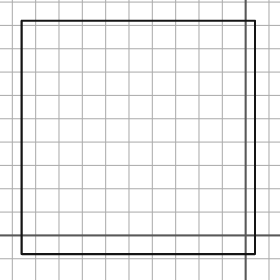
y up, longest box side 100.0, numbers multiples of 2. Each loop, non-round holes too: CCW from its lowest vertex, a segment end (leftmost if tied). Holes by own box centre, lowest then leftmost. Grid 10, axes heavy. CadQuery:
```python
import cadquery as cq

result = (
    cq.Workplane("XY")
    .moveTo(-96.0, -8.0)
    .lineTo(4.0, -8.0)
    .lineTo(4.0, 92.0)
    .lineTo(-96.0, 92.0)
    .close()
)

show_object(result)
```